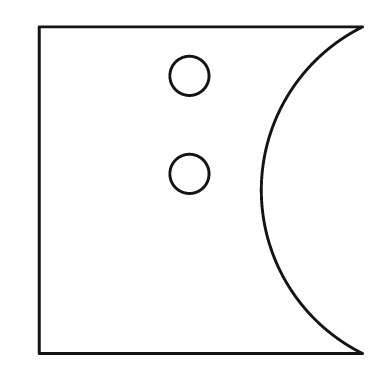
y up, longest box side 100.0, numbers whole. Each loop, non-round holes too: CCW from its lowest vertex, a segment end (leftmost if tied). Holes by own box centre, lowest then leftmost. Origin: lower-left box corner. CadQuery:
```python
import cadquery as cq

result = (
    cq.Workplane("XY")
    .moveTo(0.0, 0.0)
    .lineTo(99.0, 0.0)
    .threePointArc((68.0, 50.0), (99.0, 100.0))
    .lineTo(0.0, 100.0)
    .close()
    .moveTo(46.0, 55.0)
    .circle(6.0)
    .moveTo(46.0, 85.0)
    .circle(6.0)
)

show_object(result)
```